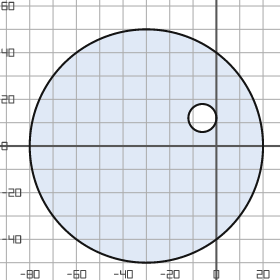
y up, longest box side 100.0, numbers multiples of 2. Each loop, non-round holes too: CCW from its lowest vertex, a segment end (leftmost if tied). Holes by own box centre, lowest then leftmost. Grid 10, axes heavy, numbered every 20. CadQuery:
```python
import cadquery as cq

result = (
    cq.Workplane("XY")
    .moveTo(-30.0, 0.0)
    .circle(50.0)
    .moveTo(-6.0, 12.0)
    .circle(6.0)
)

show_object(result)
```